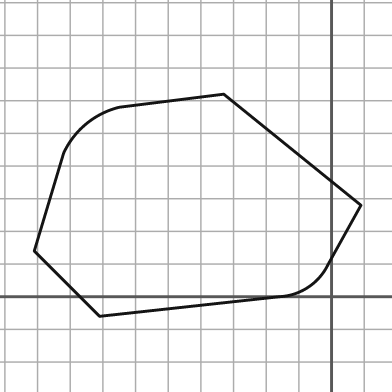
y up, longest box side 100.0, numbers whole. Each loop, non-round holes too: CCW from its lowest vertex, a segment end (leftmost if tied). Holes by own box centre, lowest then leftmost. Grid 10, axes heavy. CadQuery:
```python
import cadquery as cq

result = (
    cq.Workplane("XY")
    .moveTo(-71.0, -6.0)
    .lineTo(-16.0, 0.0)
    .threePointArc((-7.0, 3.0), (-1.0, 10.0))
    .lineTo(9.0, 28.0)
    .lineTo(-33.0, 62.0)
    .lineTo(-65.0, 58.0)
    .threePointArc((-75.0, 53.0), (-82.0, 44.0))
    .lineTo(-91.0, 14.0)
    .close()
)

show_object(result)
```